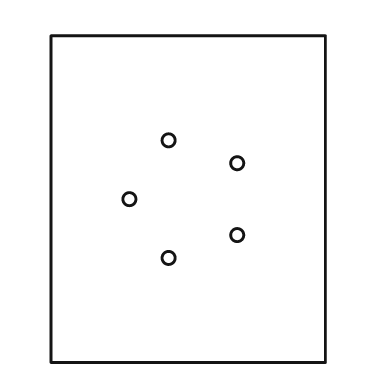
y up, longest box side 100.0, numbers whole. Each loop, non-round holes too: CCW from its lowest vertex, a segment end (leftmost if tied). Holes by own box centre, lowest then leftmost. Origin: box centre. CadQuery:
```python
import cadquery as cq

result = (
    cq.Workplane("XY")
    .moveTo(-42.0, -50.0)
    .lineTo(42.0, -50.0)
    .lineTo(42.0, 50.0)
    .lineTo(-42.0, 50.0)
    .close()
    .moveTo(-6.0, -18.0)
    .circle(2.0)
    .moveTo(15.0, -11.0)
    .circle(2.0)
    .moveTo(-18.0, 0.0)
    .circle(2.0)
    .moveTo(15.0, 11.0)
    .circle(2.0)
    .moveTo(-6.0, 18.0)
    .circle(2.0)
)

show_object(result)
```